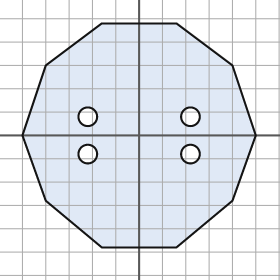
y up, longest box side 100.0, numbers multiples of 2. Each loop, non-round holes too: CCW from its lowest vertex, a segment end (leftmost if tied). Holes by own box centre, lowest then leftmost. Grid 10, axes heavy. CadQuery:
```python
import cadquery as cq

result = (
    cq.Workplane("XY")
    .moveTo(-16.0, -48.0)
    .lineTo(16.0, -48.0)
    .lineTo(40.0, -28.0)
    .lineTo(50.0, 0.0)
    .lineTo(40.0, 30.0)
    .lineTo(16.0, 48.0)
    .lineTo(-16.0, 48.0)
    .lineTo(-40.0, 30.0)
    .lineTo(-50.0, 0.0)
    .lineTo(-40.0, -28.0)
    .close()
    .moveTo(-22.0, -8.0)
    .circle(4.0)
    .moveTo(22.0, -8.0)
    .circle(4.0)
    .moveTo(-22.0, 8.0)
    .circle(4.0)
    .moveTo(22.0, 8.0)
    .circle(4.0)
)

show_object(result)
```